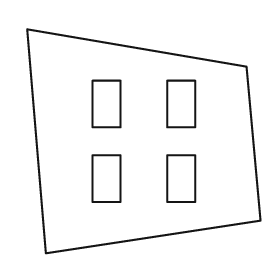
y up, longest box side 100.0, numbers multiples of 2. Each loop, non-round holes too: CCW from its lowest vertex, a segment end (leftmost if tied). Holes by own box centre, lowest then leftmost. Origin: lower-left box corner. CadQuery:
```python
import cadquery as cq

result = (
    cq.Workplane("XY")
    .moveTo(8.0, 0.0)
    .lineTo(100.0, 14.0)
    .lineTo(94.0, 80.0)
    .lineTo(0.0, 96.0)
    .close()
    .moveTo(28.0, 22.0)
    .lineTo(40.0, 22.0)
    .lineTo(40.0, 42.0)
    .lineTo(28.0, 42.0)
    .close()
    .moveTo(60.0, 22.0)
    .lineTo(72.0, 22.0)
    .lineTo(72.0, 42.0)
    .lineTo(60.0, 42.0)
    .close()
    .moveTo(28.0, 54.0)
    .lineTo(40.0, 54.0)
    .lineTo(40.0, 74.0)
    .lineTo(28.0, 74.0)
    .close()
    .moveTo(60.0, 54.0)
    .lineTo(72.0, 54.0)
    .lineTo(72.0, 74.0)
    .lineTo(60.0, 74.0)
    .close()
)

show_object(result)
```